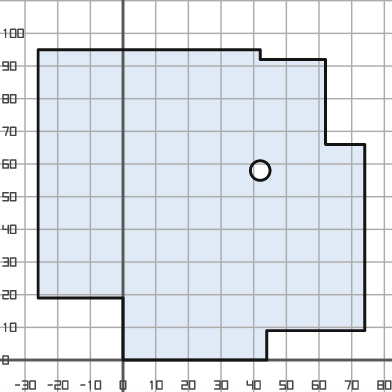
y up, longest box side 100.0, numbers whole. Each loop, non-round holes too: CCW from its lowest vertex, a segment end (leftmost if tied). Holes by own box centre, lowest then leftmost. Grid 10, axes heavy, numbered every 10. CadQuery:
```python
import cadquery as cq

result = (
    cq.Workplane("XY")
    .moveTo(0.0, 0.0)
    .lineTo(44.0, 0.0)
    .lineTo(44.0, 9.0)
    .lineTo(74.0, 9.0)
    .lineTo(74.0, 66.0)
    .lineTo(62.0, 66.0)
    .lineTo(62.0, 92.0)
    .lineTo(42.0, 92.0)
    .lineTo(42.0, 95.0)
    .lineTo(-26.0, 95.0)
    .lineTo(-26.0, 19.0)
    .lineTo(0.0, 19.0)
    .close()
    .moveTo(42.0, 58.0)
    .circle(3.0)
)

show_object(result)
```